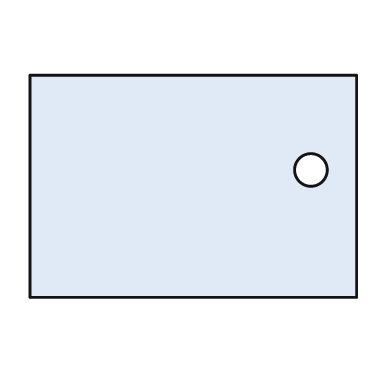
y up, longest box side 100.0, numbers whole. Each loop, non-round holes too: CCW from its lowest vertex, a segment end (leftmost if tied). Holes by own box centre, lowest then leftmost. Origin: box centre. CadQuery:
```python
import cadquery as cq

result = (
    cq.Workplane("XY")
    .moveTo(-50.0, -34.0)
    .lineTo(50.0, -34.0)
    .lineTo(50.0, 34.0)
    .lineTo(-50.0, 34.0)
    .close()
    .moveTo(36.0, 5.0)
    .circle(5.0)
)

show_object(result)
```